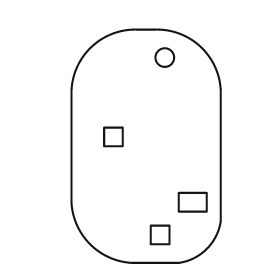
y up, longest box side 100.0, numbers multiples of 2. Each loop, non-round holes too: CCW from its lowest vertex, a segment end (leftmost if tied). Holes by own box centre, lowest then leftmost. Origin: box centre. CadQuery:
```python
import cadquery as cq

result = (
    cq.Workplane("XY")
    .moveTo(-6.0, -50.0)
    .lineTo(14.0, -50.0)
    .threePointArc((26.0, -44.0), (32.0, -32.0))
    .lineTo(32.0, 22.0)
    .threePointArc((24.0, 42.0), (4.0, 50.0))
    .lineTo(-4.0, 50.0)
    .threePointArc((-24.0, 42.0), (-32.0, 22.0))
    .lineTo(-32.0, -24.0)
    .threePointArc((-24.0, -42.0), (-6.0, -50.0))
    .close()
    .moveTo(2.0, -42.0)
    .lineTo(10.0, -42.0)
    .lineTo(10.0, -34.0)
    .lineTo(2.0, -34.0)
    .close()
    .moveTo(14.0, -28.0)
    .lineTo(26.0, -28.0)
    .lineTo(26.0, -20.0)
    .lineTo(14.0, -20.0)
    .close()
    .moveTo(-18.0, 0.0)
    .lineTo(-10.0, 0.0)
    .lineTo(-10.0, 8.0)
    .lineTo(-18.0, 8.0)
    .close()
    .moveTo(8.0, 38.0)
    .circle(4.0)
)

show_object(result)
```